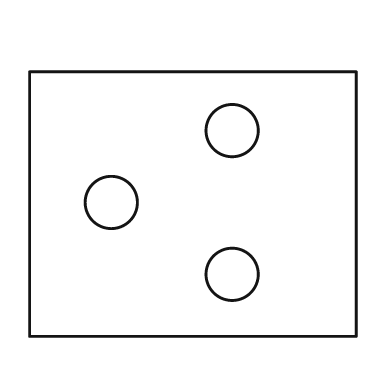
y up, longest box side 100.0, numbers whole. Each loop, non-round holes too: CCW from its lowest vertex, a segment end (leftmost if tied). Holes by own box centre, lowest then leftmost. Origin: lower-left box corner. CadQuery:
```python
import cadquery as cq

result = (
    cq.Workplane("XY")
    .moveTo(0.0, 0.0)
    .lineTo(100.0, 0.0)
    .lineTo(100.0, 81.0)
    .lineTo(0.0, 81.0)
    .close()
    .moveTo(62.0, 19.0)
    .circle(8.0)
    .moveTo(25.0, 41.0)
    .circle(8.0)
    .moveTo(62.0, 63.0)
    .circle(8.0)
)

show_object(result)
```